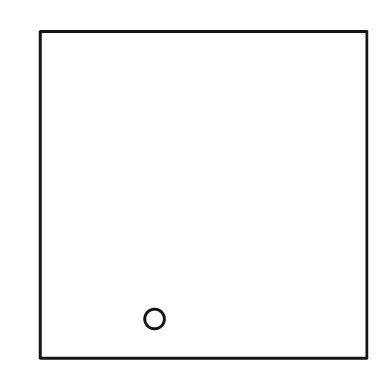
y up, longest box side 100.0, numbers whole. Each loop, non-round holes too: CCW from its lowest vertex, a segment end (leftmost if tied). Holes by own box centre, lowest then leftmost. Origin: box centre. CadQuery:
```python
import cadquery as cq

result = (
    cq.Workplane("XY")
    .moveTo(-50.0, -50.0)
    .lineTo(50.0, -50.0)
    .lineTo(50.0, 50.0)
    .lineTo(-50.0, 50.0)
    .close()
    .moveTo(-15.0, -38.0)
    .circle(3.0)
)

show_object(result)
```